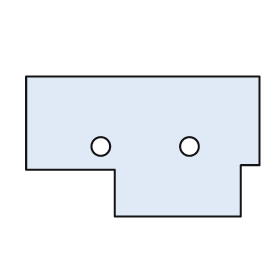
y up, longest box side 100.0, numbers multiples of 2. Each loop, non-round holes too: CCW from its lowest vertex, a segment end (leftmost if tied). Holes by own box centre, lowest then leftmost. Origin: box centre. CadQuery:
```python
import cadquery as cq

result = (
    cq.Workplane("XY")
    .moveTo(-12.0, -30.0)
    .lineTo(42.0, -30.0)
    .lineTo(42.0, -8.0)
    .lineTo(50.0, -8.0)
    .lineTo(50.0, 30.0)
    .lineTo(-50.0, 30.0)
    .lineTo(-50.0, -10.0)
    .lineTo(-12.0, -10.0)
    .close()
    .moveTo(-18.0, 0.0)
    .circle(4.0)
    .moveTo(20.0, 0.0)
    .circle(4.0)
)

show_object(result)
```